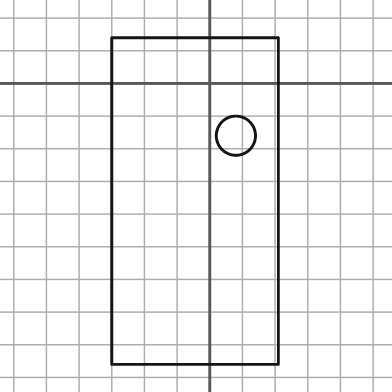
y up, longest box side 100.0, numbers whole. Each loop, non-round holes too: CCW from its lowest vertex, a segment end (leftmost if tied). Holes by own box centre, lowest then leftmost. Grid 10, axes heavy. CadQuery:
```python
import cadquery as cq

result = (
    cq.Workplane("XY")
    .moveTo(-30.0, -86.0)
    .lineTo(21.0, -86.0)
    .lineTo(21.0, 14.0)
    .lineTo(-30.0, 14.0)
    .close()
    .moveTo(8.0, -16.0)
    .circle(6.0)
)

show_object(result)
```